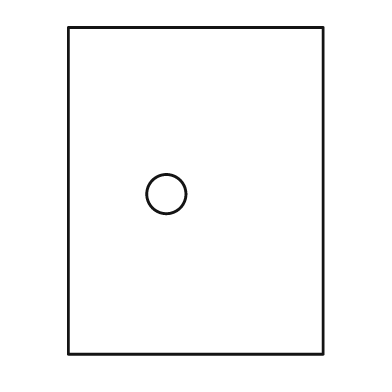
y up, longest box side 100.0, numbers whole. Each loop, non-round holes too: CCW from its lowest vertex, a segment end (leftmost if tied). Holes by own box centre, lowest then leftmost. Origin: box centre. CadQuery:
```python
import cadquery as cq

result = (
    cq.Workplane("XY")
    .moveTo(-39.0, -50.0)
    .lineTo(39.0, -50.0)
    .lineTo(39.0, 50.0)
    .lineTo(-39.0, 50.0)
    .close()
    .moveTo(-9.0, -1.0)
    .circle(6.0)
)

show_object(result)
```